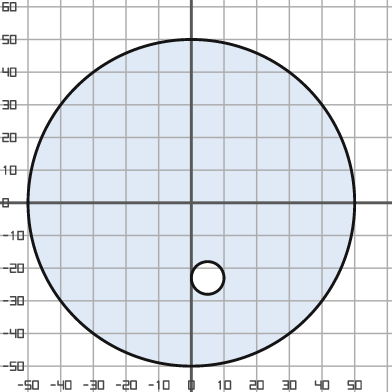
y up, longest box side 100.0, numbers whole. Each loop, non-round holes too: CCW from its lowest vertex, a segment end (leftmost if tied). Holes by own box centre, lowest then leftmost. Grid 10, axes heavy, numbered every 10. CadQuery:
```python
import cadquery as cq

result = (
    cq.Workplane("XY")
    .moveTo(0.0, 0.0)
    .circle(50.0)
    .moveTo(5.0, -23.0)
    .circle(5.0)
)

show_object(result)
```